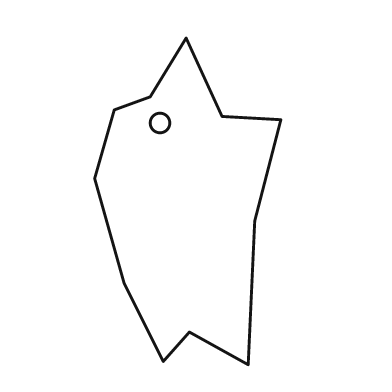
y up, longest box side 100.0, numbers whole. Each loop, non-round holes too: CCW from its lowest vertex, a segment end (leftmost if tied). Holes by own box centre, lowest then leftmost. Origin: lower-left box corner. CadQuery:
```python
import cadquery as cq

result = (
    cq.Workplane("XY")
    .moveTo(47.0, 0.0)
    .lineTo(49.0, 44.0)
    .lineTo(57.0, 75.0)
    .lineTo(39.0, 76.0)
    .lineTo(28.0, 100.0)
    .lineTo(17.0, 82.0)
    .lineTo(6.0, 78.0)
    .lineTo(0.0, 57.0)
    .lineTo(9.0, 25.0)
    .lineTo(21.0, 1.0)
    .lineTo(29.0, 10.0)
    .close()
    .moveTo(20.0, 74.0)
    .circle(3.0)
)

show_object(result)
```